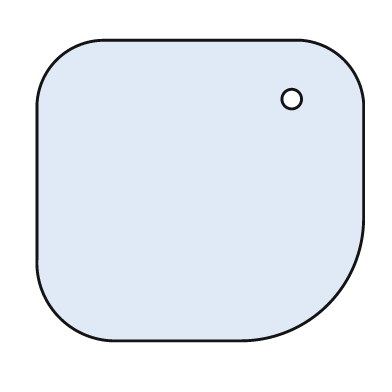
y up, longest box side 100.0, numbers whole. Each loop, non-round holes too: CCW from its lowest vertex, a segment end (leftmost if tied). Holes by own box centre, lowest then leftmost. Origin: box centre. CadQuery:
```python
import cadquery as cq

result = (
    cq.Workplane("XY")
    .moveTo(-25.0, -46.0)
    .lineTo(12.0, -46.0)
    .threePointArc((39.0, -35.0), (50.0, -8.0))
    .lineTo(50.0, 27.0)
    .threePointArc((44.0, 40.0), (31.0, 46.0))
    .lineTo(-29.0, 46.0)
    .threePointArc((-44.0, 40.0), (-50.0, 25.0))
    .lineTo(-50.0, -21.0)
    .threePointArc((-43.0, -39.0), (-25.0, -46.0))
    .close()
    .moveTo(28.0, 28.0)
    .circle(3.0)
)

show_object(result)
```